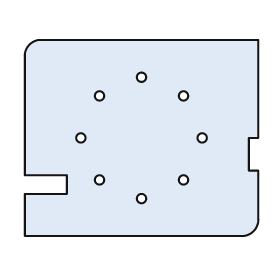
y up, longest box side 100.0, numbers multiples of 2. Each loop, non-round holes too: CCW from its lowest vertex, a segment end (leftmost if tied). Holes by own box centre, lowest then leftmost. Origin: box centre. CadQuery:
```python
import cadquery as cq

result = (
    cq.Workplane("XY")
    .moveTo(-50.0, -42.0)
    .lineTo(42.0, -42.0)
    .threePointArc((48.0, -40.0), (50.0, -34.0))
    .lineTo(50.0, -14.0)
    .lineTo(46.0, -14.0)
    .lineTo(46.0, 0.0)
    .lineTo(50.0, 0.0)
    .lineTo(50.0, 42.0)
    .lineTo(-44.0, 42.0)
    .threePointArc((-48.0, 40.0), (-50.0, 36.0))
    .lineTo(-50.0, -16.0)
    .lineTo(-32.0, -16.0)
    .lineTo(-32.0, -24.0)
    .lineTo(-50.0, -24.0)
    .close()
    .moveTo(0.0, -26.0)
    .circle(2.0)
    .moveTo(-18.0, -18.0)
    .circle(2.0)
    .moveTo(18.0, -18.0)
    .circle(2.0)
    .moveTo(-26.0, 0.0)
    .circle(2.0)
    .moveTo(26.0, 0.0)
    .circle(2.0)
    .moveTo(-18.0, 18.0)
    .circle(2.0)
    .moveTo(18.0, 18.0)
    .circle(2.0)
    .moveTo(0.0, 26.0)
    .circle(2.0)
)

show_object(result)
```